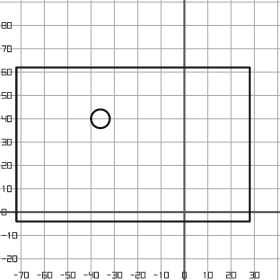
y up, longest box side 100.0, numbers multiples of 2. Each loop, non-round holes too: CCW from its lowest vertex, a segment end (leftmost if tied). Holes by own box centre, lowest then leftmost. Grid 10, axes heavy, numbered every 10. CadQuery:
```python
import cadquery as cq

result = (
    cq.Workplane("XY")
    .moveTo(-72.0, -4.0)
    .lineTo(28.0, -4.0)
    .lineTo(28.0, 62.0)
    .lineTo(-72.0, 62.0)
    .close()
    .moveTo(-36.0, 40.0)
    .circle(4.0)
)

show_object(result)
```